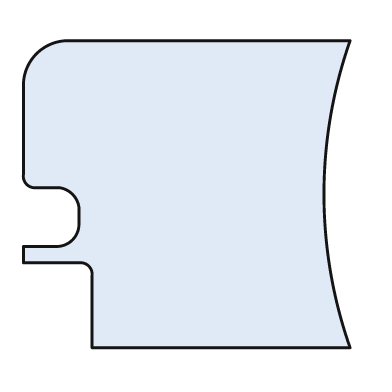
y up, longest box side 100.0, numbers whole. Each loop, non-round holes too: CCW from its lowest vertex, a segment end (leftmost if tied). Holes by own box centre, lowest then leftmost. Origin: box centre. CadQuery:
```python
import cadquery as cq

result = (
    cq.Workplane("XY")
    .moveTo(-29.0, -47.0)
    .lineTo(50.0, -47.0)
    .threePointArc((42.0, 0.0), (50.0, 47.0))
    .lineTo(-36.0, 47.0)
    .threePointArc((-46.0, 43.0), (-50.0, 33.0))
    .lineTo(-50.0, 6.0)
    .threePointArc((-49.0, 3.0), (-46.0, 2.0))
    .lineTo(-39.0, 2.0)
    .threePointArc((-35.0, 0.0), (-33.0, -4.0))
    .lineTo(-33.0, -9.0)
    .threePointArc((-35.0, -14.0), (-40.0, -16.0))
    .lineTo(-50.0, -16.0)
    .lineTo(-50.0, -21.0)
    .lineTo(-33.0, -21.0)
    .threePointArc((-30.0, -22.0), (-29.0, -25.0))
    .close()
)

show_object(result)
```